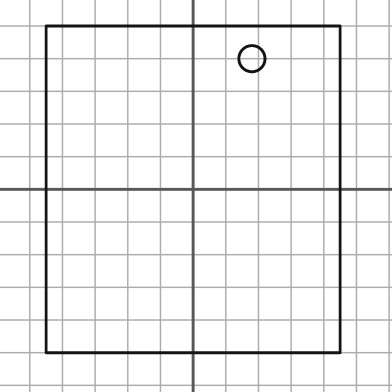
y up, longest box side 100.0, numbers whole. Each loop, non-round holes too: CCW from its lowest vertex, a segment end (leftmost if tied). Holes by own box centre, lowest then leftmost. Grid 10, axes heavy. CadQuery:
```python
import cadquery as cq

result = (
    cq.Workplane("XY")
    .moveTo(-45.0, -50.0)
    .lineTo(45.0, -50.0)
    .lineTo(45.0, 50.0)
    .lineTo(-45.0, 50.0)
    .close()
    .moveTo(18.0, 40.0)
    .circle(4.0)
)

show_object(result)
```